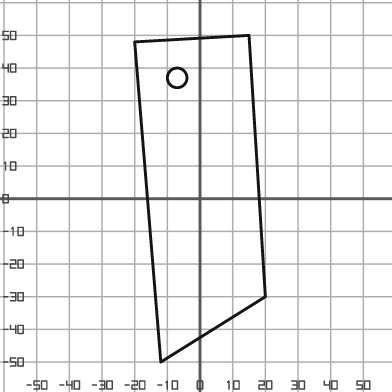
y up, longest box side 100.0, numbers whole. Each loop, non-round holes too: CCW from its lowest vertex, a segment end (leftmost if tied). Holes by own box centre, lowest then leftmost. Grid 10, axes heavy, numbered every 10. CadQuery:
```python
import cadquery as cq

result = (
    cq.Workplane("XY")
    .moveTo(-12.0, -50.0)
    .lineTo(20.0, -30.0)
    .lineTo(15.0, 50.0)
    .lineTo(-20.0, 48.0)
    .close()
    .moveTo(-7.0, 37.0)
    .circle(3.0)
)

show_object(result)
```